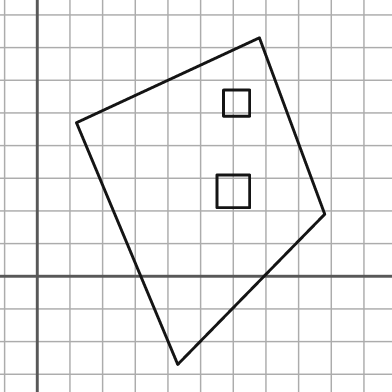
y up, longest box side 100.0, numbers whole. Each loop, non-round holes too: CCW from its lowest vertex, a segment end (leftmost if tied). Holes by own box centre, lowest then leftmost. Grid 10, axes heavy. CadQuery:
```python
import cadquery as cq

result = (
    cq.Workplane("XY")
    .moveTo(43.0, -27.0)
    .lineTo(88.0, 19.0)
    .lineTo(68.0, 73.0)
    .lineTo(12.0, 47.0)
    .close()
    .moveTo(55.0, 21.0)
    .lineTo(65.0, 21.0)
    .lineTo(65.0, 31.0)
    .lineTo(55.0, 31.0)
    .close()
    .moveTo(57.0, 49.0)
    .lineTo(65.0, 49.0)
    .lineTo(65.0, 57.0)
    .lineTo(57.0, 57.0)
    .close()
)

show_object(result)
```